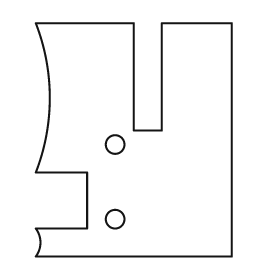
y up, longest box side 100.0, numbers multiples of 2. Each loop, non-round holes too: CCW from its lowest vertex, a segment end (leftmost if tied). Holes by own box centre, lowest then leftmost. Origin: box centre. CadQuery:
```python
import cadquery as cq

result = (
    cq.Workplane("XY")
    .moveTo(-42.0, -50.0)
    .lineTo(42.0, -50.0)
    .lineTo(42.0, 50.0)
    .lineTo(12.0, 50.0)
    .lineTo(12.0, 4.0)
    .lineTo(0.0, 4.0)
    .lineTo(0.0, 50.0)
    .lineTo(-42.0, 50.0)
    .threePointArc((-36.0, 18.0), (-42.0, -14.0))
    .lineTo(-20.0, -14.0)
    .lineTo(-20.0, -38.0)
    .lineTo(-42.0, -38.0)
    .threePointArc((-40.0, -44.0), (-42.0, -50.0))
    .close()
    .moveTo(-8.0, -34.0)
    .circle(4.0)
    .moveTo(-8.0, -2.0)
    .circle(4.0)
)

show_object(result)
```